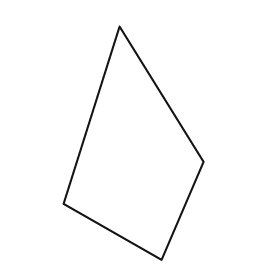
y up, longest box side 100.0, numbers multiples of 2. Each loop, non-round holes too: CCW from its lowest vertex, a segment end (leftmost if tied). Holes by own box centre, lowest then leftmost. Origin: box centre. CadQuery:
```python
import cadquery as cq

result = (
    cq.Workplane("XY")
    .moveTo(12.0, -50.0)
    .lineTo(30.0, -8.0)
    .lineTo(-6.0, 50.0)
    .lineTo(-30.0, -26.0)
    .close()
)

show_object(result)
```